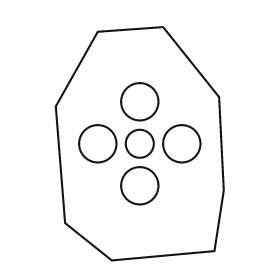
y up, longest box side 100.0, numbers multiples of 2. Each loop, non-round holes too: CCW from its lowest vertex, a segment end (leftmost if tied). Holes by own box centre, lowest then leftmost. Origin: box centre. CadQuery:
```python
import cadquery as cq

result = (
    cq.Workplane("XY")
    .moveTo(-12.0, -50.0)
    .lineTo(32.0, -46.0)
    .lineTo(36.0, -20.0)
    .lineTo(34.0, 20.0)
    .lineTo(10.0, 50.0)
    .lineTo(-18.0, 48.0)
    .lineTo(-36.0, 16.0)
    .lineTo(-32.0, -34.0)
    .close()
    .moveTo(0.0, -18.0)
    .circle(8.0)
    .moveTo(-18.0, 0.0)
    .circle(8.0)
    .moveTo(0.0, 0.0)
    .circle(6.0)
    .moveTo(18.0, 0.0)
    .circle(8.0)
    .moveTo(0.0, 18.0)
    .circle(8.0)
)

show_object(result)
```